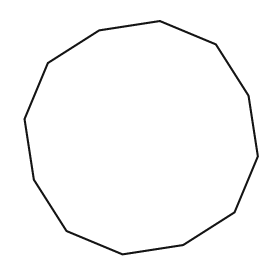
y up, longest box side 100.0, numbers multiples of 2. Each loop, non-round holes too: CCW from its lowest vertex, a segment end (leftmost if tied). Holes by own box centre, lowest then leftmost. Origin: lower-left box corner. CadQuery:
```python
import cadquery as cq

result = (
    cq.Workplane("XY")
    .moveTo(42.0, 0.0)
    .lineTo(68.0, 4.0)
    .lineTo(90.0, 18.0)
    .lineTo(100.0, 42.0)
    .lineTo(96.0, 68.0)
    .lineTo(82.0, 90.0)
    .lineTo(58.0, 100.0)
    .lineTo(32.0, 96.0)
    .lineTo(10.0, 82.0)
    .lineTo(0.0, 58.0)
    .lineTo(4.0, 32.0)
    .lineTo(18.0, 10.0)
    .close()
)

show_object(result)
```